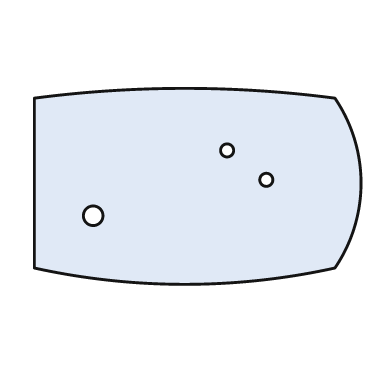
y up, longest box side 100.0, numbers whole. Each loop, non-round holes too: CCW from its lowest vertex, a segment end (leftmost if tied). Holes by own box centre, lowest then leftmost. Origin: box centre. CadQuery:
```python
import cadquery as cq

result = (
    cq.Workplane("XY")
    .moveTo(-50.0, -25.0)
    .threePointArc((-4.0, -30.0), (42.0, -25.0))
    .threePointArc((50.0, 1.0), (42.0, 27.0))
    .threePointArc((-4.0, 30.0), (-50.0, 27.0))
    .close()
    .moveTo(-32.0, -9.0)
    .circle(3.0)
    .moveTo(21.0, 2.0)
    .circle(2.0)
    .moveTo(9.0, 11.0)
    .circle(2.0)
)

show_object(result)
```